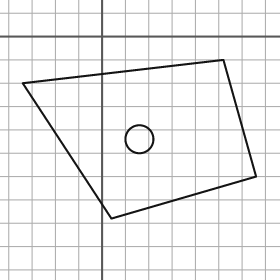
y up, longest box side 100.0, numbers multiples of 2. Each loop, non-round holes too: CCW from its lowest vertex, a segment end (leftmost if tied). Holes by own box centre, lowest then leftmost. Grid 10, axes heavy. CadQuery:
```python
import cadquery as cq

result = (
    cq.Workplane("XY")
    .moveTo(4.0, -78.0)
    .lineTo(66.0, -60.0)
    .lineTo(52.0, -10.0)
    .lineTo(-34.0, -20.0)
    .close()
    .moveTo(16.0, -44.0)
    .circle(6.0)
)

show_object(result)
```